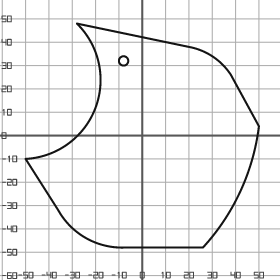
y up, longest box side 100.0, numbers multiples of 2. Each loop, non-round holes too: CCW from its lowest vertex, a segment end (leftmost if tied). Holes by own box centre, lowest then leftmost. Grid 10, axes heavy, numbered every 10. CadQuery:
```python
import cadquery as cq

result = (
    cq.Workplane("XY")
    .moveTo(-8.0, -48.0)
    .lineTo(26.0, -48.0)
    .threePointArc((42.0, -24.0), (50.0, 4.0))
    .lineTo(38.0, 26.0)
    .threePointArc((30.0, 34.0), (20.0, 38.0))
    .lineTo(-28.0, 48.0)
    .threePointArc((-20.0, 12.0), (-50.0, -10.0))
    .lineTo(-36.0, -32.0)
    .threePointArc((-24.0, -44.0), (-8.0, -48.0))
    .close()
    .moveTo(-8.0, 32.0)
    .circle(2.0)
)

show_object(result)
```